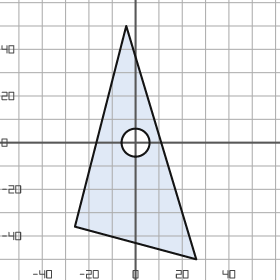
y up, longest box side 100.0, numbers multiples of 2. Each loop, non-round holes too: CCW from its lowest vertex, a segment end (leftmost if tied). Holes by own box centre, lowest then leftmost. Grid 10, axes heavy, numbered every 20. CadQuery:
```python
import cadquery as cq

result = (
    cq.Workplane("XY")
    .moveTo(26.0, -50.0)
    .lineTo(-4.0, 50.0)
    .lineTo(-26.0, -36.0)
    .close()
    .moveTo(0.0, 0.0)
    .circle(6.0)
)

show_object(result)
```